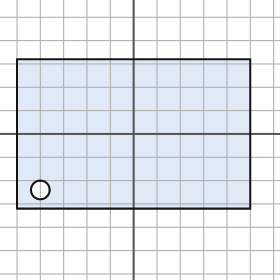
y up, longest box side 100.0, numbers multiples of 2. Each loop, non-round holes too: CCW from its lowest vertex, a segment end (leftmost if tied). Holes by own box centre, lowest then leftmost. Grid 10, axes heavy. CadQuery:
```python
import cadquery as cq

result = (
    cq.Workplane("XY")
    .moveTo(-50.0, -32.0)
    .lineTo(50.0, -32.0)
    .lineTo(50.0, 32.0)
    .lineTo(-50.0, 32.0)
    .close()
    .moveTo(-40.0, -24.0)
    .circle(4.0)
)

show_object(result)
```